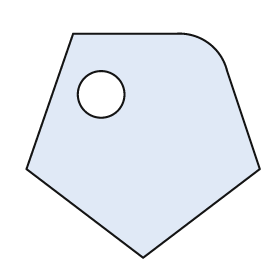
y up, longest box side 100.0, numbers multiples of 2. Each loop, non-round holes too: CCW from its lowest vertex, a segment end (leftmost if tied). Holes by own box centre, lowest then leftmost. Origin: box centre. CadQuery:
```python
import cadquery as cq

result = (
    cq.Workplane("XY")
    .moveTo(0.0, -48.0)
    .lineTo(50.0, -10.0)
    .lineTo(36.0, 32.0)
    .threePointArc((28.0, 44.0), (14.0, 48.0))
    .lineTo(-30.0, 48.0)
    .lineTo(-50.0, -10.0)
    .close()
    .moveTo(-18.0, 22.0)
    .circle(10.0)
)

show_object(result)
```